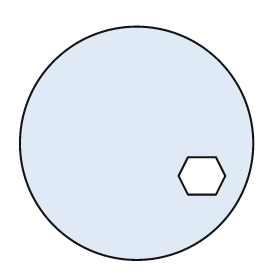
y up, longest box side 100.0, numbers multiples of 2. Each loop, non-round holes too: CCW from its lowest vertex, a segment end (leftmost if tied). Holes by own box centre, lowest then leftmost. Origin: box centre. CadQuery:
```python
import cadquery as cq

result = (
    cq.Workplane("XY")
    .moveTo(0.0, 0.0)
    .circle(50.0)
    .moveTo(22.0, -22.0)
    .lineTo(34.0, -22.0)
    .lineTo(38.0, -14.0)
    .lineTo(34.0, -6.0)
    .lineTo(22.0, -6.0)
    .lineTo(18.0, -14.0)
    .close()
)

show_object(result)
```